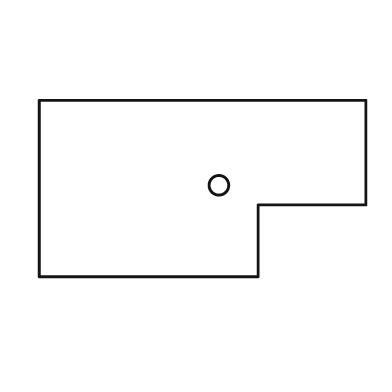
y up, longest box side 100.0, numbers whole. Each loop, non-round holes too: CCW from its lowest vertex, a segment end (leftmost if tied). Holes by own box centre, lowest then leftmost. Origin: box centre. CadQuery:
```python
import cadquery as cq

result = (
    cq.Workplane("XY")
    .moveTo(-50.0, -27.0)
    .lineTo(17.0, -27.0)
    .lineTo(17.0, -5.0)
    .lineTo(50.0, -5.0)
    .lineTo(50.0, 27.0)
    .lineTo(-50.0, 27.0)
    .close()
    .moveTo(5.0, 1.0)
    .circle(3.0)
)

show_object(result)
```